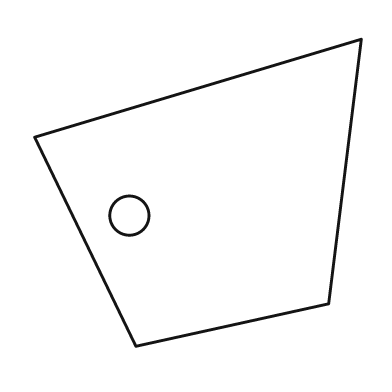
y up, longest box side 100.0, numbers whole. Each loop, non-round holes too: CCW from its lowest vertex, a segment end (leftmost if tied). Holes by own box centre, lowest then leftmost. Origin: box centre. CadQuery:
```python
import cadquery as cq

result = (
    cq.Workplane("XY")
    .moveTo(-19.0, -47.0)
    .lineTo(40.0, -34.0)
    .lineTo(50.0, 47.0)
    .lineTo(-50.0, 17.0)
    .close()
    .moveTo(-21.0, -7.0)
    .circle(6.0)
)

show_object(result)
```